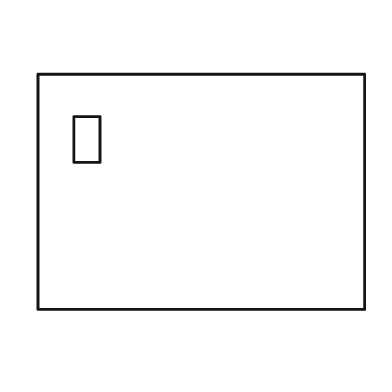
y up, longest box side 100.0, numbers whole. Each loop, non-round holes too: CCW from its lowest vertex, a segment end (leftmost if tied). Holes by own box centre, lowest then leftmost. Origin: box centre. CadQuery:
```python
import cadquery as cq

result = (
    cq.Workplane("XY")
    .moveTo(-50.0, -36.0)
    .lineTo(50.0, -36.0)
    .lineTo(50.0, 36.0)
    .lineTo(-50.0, 36.0)
    .close()
    .moveTo(-39.0, 9.0)
    .lineTo(-31.0, 9.0)
    .lineTo(-31.0, 23.0)
    .lineTo(-39.0, 23.0)
    .close()
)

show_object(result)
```